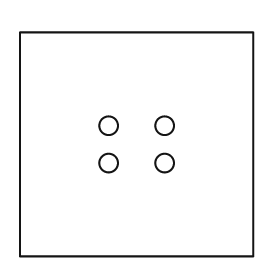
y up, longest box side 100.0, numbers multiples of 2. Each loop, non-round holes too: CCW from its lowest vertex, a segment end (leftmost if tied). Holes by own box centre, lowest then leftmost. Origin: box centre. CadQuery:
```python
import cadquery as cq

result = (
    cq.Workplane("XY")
    .moveTo(-50.0, -48.0)
    .lineTo(50.0, -48.0)
    .lineTo(50.0, 48.0)
    .lineTo(-50.0, 48.0)
    .close()
    .moveTo(-12.0, -8.0)
    .circle(4.0)
    .moveTo(12.0, -8.0)
    .circle(4.0)
    .moveTo(-12.0, 8.0)
    .circle(4.0)
    .moveTo(12.0, 8.0)
    .circle(4.0)
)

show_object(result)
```